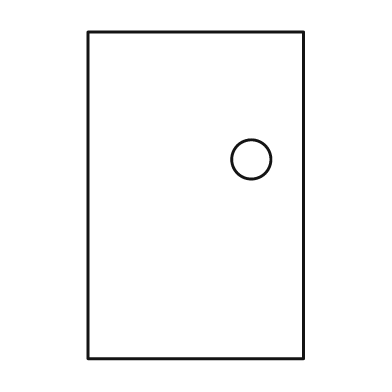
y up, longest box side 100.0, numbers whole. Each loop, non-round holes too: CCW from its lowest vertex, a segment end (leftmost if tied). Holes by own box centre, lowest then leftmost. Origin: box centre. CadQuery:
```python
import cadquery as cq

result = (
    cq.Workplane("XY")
    .moveTo(-33.0, -50.0)
    .lineTo(33.0, -50.0)
    .lineTo(33.0, 50.0)
    .lineTo(-33.0, 50.0)
    .close()
    .moveTo(17.0, 11.0)
    .circle(6.0)
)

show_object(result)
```